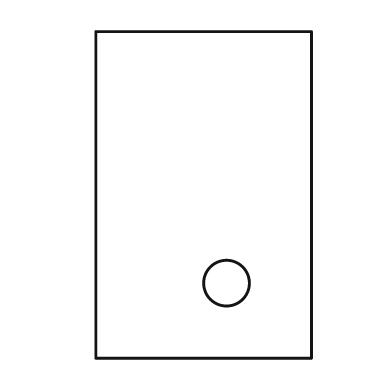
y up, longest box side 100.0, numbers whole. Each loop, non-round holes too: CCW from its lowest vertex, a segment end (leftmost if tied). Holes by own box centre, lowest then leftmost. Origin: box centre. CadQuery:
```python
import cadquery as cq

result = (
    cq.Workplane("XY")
    .moveTo(-33.0, -50.0)
    .lineTo(33.0, -50.0)
    .lineTo(33.0, 50.0)
    .lineTo(-33.0, 50.0)
    .close()
    .moveTo(7.0, -27.0)
    .circle(7.0)
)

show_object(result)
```